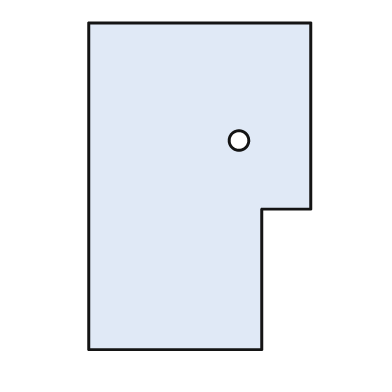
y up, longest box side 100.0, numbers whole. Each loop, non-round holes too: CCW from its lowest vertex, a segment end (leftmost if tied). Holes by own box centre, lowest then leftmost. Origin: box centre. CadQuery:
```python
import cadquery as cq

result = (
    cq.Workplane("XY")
    .moveTo(-34.0, -50.0)
    .lineTo(19.0, -50.0)
    .lineTo(19.0, -7.0)
    .lineTo(34.0, -7.0)
    .lineTo(34.0, 50.0)
    .lineTo(-34.0, 50.0)
    .close()
    .moveTo(12.0, 14.0)
    .circle(3.0)
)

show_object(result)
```